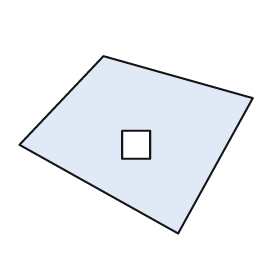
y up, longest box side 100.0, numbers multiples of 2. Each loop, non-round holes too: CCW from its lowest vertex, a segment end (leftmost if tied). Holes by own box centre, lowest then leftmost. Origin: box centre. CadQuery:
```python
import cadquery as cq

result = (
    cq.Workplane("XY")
    .moveTo(18.0, -38.0)
    .lineTo(50.0, 20.0)
    .lineTo(-14.0, 38.0)
    .lineTo(-50.0, 0.0)
    .close()
    .moveTo(-6.0, -6.0)
    .lineTo(6.0, -6.0)
    .lineTo(6.0, 6.0)
    .lineTo(-6.0, 6.0)
    .close()
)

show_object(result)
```